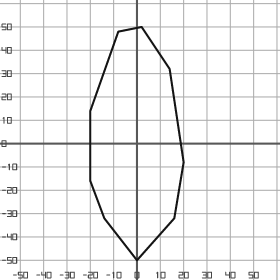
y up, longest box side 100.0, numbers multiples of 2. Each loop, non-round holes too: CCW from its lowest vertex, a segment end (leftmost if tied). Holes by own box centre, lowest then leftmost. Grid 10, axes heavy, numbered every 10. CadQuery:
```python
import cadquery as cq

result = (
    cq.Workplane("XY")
    .moveTo(0.0, -50.0)
    .lineTo(16.0, -32.0)
    .lineTo(20.0, -8.0)
    .lineTo(14.0, 32.0)
    .lineTo(2.0, 50.0)
    .lineTo(-8.0, 48.0)
    .lineTo(-20.0, 14.0)
    .lineTo(-20.0, -16.0)
    .lineTo(-14.0, -32.0)
    .close()
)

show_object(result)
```